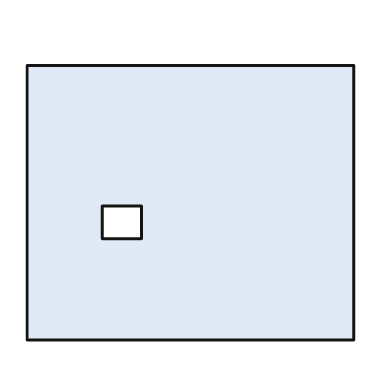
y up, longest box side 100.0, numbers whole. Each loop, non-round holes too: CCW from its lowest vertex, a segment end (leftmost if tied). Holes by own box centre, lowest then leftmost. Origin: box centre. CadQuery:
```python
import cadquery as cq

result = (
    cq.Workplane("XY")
    .moveTo(-50.0, -42.0)
    .lineTo(50.0, -42.0)
    .lineTo(50.0, 42.0)
    .lineTo(-50.0, 42.0)
    .close()
    .moveTo(-27.0, -11.0)
    .lineTo(-15.0, -11.0)
    .lineTo(-15.0, -1.0)
    .lineTo(-27.0, -1.0)
    .close()
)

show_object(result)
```